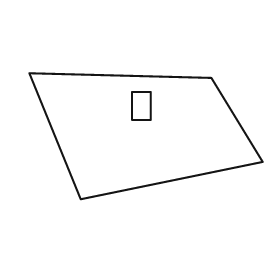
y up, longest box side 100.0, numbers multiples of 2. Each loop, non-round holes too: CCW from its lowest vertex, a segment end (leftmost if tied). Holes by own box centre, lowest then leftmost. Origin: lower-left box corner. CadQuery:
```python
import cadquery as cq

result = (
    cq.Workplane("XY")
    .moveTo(22.0, 0.0)
    .lineTo(100.0, 16.0)
    .lineTo(78.0, 52.0)
    .lineTo(0.0, 54.0)
    .close()
    .moveTo(44.0, 34.0)
    .lineTo(52.0, 34.0)
    .lineTo(52.0, 46.0)
    .lineTo(44.0, 46.0)
    .close()
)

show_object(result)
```